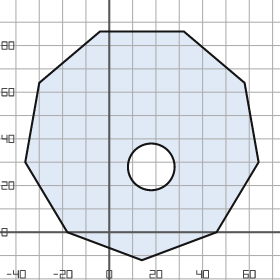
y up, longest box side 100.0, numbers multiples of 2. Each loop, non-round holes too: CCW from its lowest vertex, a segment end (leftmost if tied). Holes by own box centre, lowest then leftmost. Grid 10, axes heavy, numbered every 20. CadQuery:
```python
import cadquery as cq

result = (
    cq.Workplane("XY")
    .moveTo(14.0, -12.0)
    .lineTo(46.0, 0.0)
    .lineTo(64.0, 30.0)
    .lineTo(58.0, 64.0)
    .lineTo(32.0, 86.0)
    .lineTo(-4.0, 86.0)
    .lineTo(-30.0, 64.0)
    .lineTo(-36.0, 30.0)
    .lineTo(-18.0, 0.0)
    .close()
    .moveTo(18.0, 28.0)
    .circle(10.0)
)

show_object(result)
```